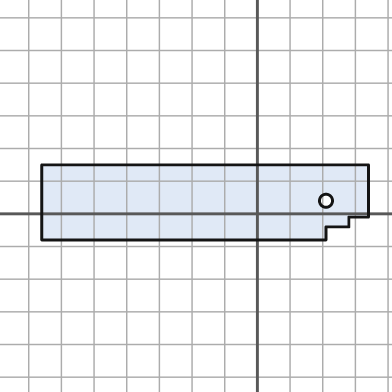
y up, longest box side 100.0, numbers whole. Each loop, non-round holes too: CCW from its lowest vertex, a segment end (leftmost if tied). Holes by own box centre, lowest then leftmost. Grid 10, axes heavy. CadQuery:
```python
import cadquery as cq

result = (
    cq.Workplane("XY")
    .moveTo(-66.0, -8.0)
    .lineTo(21.0, -8.0)
    .lineTo(21.0, -4.0)
    .lineTo(28.0, -4.0)
    .lineTo(28.0, -1.0)
    .lineTo(34.0, -1.0)
    .lineTo(34.0, 15.0)
    .lineTo(-66.0, 15.0)
    .close()
    .moveTo(21.0, 4.0)
    .circle(2.0)
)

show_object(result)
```